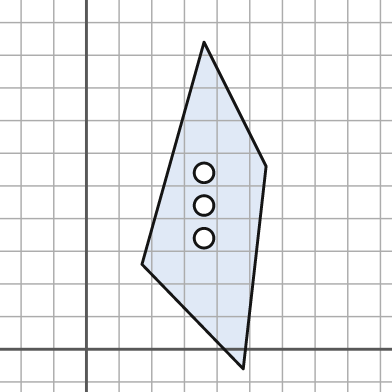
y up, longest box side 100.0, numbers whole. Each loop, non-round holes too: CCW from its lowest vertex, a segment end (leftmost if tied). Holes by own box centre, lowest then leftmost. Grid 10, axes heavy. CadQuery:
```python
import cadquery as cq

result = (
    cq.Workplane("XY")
    .moveTo(48.0, -6.0)
    .lineTo(55.0, 56.0)
    .lineTo(36.0, 94.0)
    .lineTo(17.0, 26.0)
    .close()
    .moveTo(36.0, 34.0)
    .circle(3.0)
    .moveTo(36.0, 44.0)
    .circle(3.0)
    .moveTo(36.0, 54.0)
    .circle(3.0)
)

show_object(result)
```